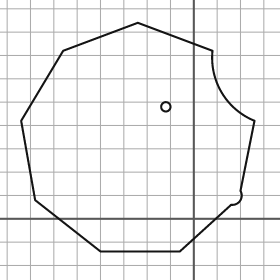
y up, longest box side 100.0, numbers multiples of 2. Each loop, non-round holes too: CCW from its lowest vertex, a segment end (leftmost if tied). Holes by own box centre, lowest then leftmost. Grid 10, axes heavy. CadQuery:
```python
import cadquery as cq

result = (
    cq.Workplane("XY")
    .moveTo(-40.0, -14.0)
    .lineTo(-6.0, -14.0)
    .lineTo(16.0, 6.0)
    .threePointArc((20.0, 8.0), (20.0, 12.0))
    .lineTo(26.0, 42.0)
    .threePointArc((12.0, 54.0), (8.0, 72.0))
    .lineTo(-24.0, 84.0)
    .lineTo(-56.0, 72.0)
    .lineTo(-74.0, 42.0)
    .lineTo(-68.0, 8.0)
    .close()
    .moveTo(-12.0, 48.0)
    .circle(2.0)
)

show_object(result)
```